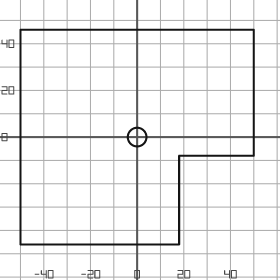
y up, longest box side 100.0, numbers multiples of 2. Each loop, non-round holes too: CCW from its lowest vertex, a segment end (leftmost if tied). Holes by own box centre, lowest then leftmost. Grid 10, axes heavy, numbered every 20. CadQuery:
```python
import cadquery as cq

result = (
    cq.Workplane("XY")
    .moveTo(-50.0, -46.0)
    .lineTo(18.0, -46.0)
    .lineTo(18.0, -8.0)
    .lineTo(50.0, -8.0)
    .lineTo(50.0, 46.0)
    .lineTo(-50.0, 46.0)
    .close()
    .moveTo(0.0, 0.0)
    .circle(4.0)
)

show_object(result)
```